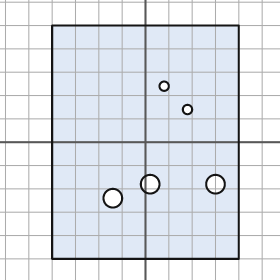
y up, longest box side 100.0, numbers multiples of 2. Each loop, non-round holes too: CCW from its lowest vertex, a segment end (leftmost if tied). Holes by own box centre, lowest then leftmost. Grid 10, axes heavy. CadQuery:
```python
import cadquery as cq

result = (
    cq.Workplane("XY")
    .moveTo(-40.0, -50.0)
    .lineTo(40.0, -50.0)
    .lineTo(40.0, 50.0)
    .lineTo(-40.0, 50.0)
    .close()
    .moveTo(-14.0, -24.0)
    .circle(4.0)
    .moveTo(2.0, -18.0)
    .circle(4.0)
    .moveTo(30.0, -18.0)
    .circle(4.0)
    .moveTo(18.0, 14.0)
    .circle(2.0)
    .moveTo(8.0, 24.0)
    .circle(2.0)
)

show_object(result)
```